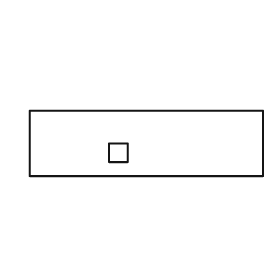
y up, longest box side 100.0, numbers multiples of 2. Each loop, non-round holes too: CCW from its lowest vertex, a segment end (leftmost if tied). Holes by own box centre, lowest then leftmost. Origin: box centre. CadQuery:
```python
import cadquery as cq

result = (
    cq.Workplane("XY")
    .moveTo(-50.0, -14.0)
    .lineTo(50.0, -14.0)
    .lineTo(50.0, 14.0)
    .lineTo(-50.0, 14.0)
    .close()
    .moveTo(-16.0, -8.0)
    .lineTo(-8.0, -8.0)
    .lineTo(-8.0, 0.0)
    .lineTo(-16.0, 0.0)
    .close()
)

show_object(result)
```